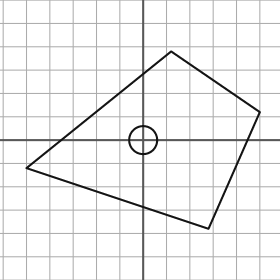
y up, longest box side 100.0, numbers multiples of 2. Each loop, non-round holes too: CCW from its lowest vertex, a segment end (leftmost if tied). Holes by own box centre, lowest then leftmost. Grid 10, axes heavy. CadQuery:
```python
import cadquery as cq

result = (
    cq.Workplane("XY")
    .moveTo(28.0, -38.0)
    .lineTo(50.0, 12.0)
    .lineTo(12.0, 38.0)
    .lineTo(-50.0, -12.0)
    .close()
    .moveTo(0.0, 0.0)
    .circle(6.0)
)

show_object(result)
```